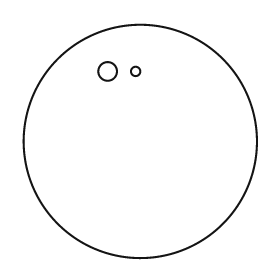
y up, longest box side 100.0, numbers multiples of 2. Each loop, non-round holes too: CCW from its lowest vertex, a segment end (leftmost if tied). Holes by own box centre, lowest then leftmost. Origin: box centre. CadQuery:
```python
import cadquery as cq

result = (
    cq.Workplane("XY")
    .moveTo(0.0, 0.0)
    .circle(50.0)
    .moveTo(-14.0, 30.0)
    .circle(4.0)
    .moveTo(-2.0, 30.0)
    .circle(2.0)
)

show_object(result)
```